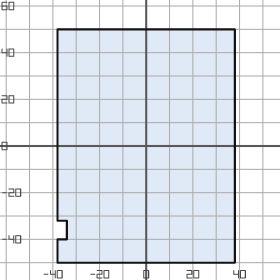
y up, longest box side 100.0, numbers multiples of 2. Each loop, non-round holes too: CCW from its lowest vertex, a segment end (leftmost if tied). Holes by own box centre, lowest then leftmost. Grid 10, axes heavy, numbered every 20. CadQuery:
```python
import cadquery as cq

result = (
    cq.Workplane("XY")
    .moveTo(-38.0, -50.0)
    .lineTo(38.0, -50.0)
    .lineTo(38.0, 50.0)
    .lineTo(-38.0, 50.0)
    .lineTo(-38.0, -32.0)
    .lineTo(-34.0, -32.0)
    .lineTo(-34.0, -40.0)
    .lineTo(-38.0, -40.0)
    .close()
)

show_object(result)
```